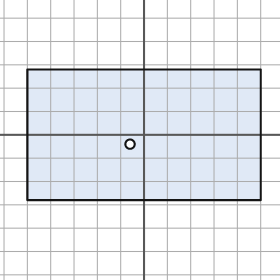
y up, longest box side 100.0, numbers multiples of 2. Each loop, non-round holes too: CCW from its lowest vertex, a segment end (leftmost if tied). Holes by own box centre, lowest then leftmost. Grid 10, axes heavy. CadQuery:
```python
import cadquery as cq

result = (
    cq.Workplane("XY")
    .moveTo(-50.0, -28.0)
    .lineTo(50.0, -28.0)
    .lineTo(50.0, 28.0)
    .lineTo(-50.0, 28.0)
    .close()
    .moveTo(-6.0, -4.0)
    .circle(2.0)
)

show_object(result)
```